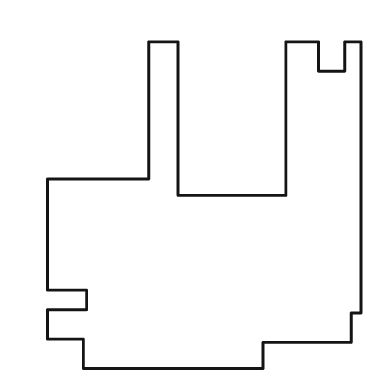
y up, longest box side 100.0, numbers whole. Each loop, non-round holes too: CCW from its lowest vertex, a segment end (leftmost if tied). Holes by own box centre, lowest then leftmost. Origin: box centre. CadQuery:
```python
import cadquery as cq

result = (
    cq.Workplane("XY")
    .moveTo(-37.0, -50.0)
    .lineTo(18.0, -50.0)
    .lineTo(18.0, -42.0)
    .lineTo(45.0, -42.0)
    .lineTo(45.0, -33.0)
    .lineTo(48.0, -33.0)
    .lineTo(48.0, 50.0)
    .lineTo(43.0, 50.0)
    .lineTo(43.0, 41.0)
    .lineTo(35.0, 41.0)
    .lineTo(35.0, 50.0)
    .lineTo(25.0, 50.0)
    .lineTo(25.0, 3.0)
    .lineTo(-8.0, 3.0)
    .lineTo(-8.0, 50.0)
    .lineTo(-17.0, 50.0)
    .lineTo(-17.0, 8.0)
    .lineTo(-48.0, 8.0)
    .lineTo(-48.0, -26.0)
    .lineTo(-36.0, -26.0)
    .lineTo(-36.0, -32.0)
    .lineTo(-48.0, -32.0)
    .lineTo(-48.0, -41.0)
    .lineTo(-37.0, -41.0)
    .close()
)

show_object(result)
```